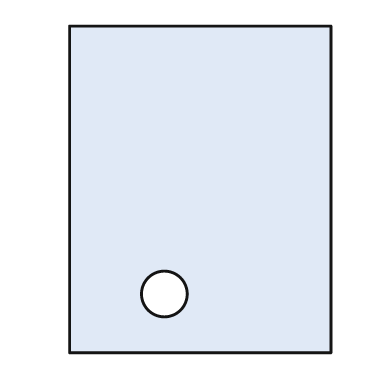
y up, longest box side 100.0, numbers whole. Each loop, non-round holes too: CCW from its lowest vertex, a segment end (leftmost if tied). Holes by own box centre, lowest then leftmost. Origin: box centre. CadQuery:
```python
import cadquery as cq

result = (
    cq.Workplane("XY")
    .moveTo(-40.0, -50.0)
    .lineTo(40.0, -50.0)
    .lineTo(40.0, 50.0)
    .lineTo(-40.0, 50.0)
    .close()
    .moveTo(-11.0, -32.0)
    .circle(7.0)
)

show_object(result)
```